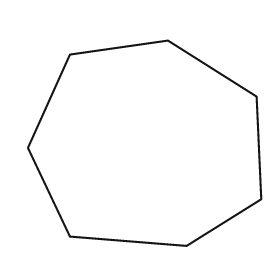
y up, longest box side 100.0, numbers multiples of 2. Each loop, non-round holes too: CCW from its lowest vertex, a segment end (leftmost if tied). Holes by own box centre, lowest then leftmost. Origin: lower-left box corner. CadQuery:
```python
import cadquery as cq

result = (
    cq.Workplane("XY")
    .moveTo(68.0, 0.0)
    .lineTo(100.0, 20.0)
    .lineTo(98.0, 64.0)
    .lineTo(60.0, 88.0)
    .lineTo(18.0, 82.0)
    .lineTo(0.0, 42.0)
    .lineTo(18.0, 4.0)
    .close()
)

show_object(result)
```